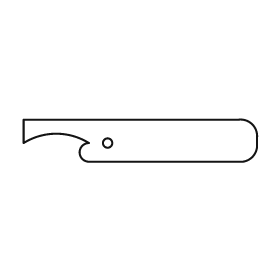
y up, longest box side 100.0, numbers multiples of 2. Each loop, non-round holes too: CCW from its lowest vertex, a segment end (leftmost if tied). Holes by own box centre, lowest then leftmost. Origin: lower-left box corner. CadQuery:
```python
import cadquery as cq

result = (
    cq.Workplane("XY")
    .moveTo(28.0, 0.0)
    .lineTo(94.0, 0.0)
    .threePointArc((98.0, 2.0), (100.0, 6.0))
    .lineTo(100.0, 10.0)
    .threePointArc((98.0, 16.0), (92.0, 18.0))
    .lineTo(0.0, 18.0)
    .lineTo(0.0, 8.0)
    .threePointArc((14.0, 12.0), (28.0, 8.0))
    .threePointArc((24.0, 4.0), (28.0, 0.0))
    .close()
    .moveTo(36.0, 8.0)
    .circle(2.0)
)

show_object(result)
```